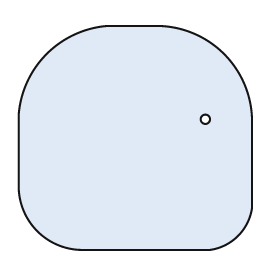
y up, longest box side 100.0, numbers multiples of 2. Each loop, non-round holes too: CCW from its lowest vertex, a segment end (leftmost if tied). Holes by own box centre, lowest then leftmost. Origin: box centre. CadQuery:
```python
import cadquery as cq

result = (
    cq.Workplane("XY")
    .moveTo(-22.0, -48.0)
    .lineTo(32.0, -48.0)
    .threePointArc((44.0, -42.0), (50.0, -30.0))
    .lineTo(50.0, 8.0)
    .threePointArc((38.0, 36.0), (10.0, 48.0))
    .lineTo(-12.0, 48.0)
    .threePointArc((-38.0, 36.0), (-50.0, 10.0))
    .lineTo(-50.0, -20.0)
    .threePointArc((-42.0, -40.0), (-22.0, -48.0))
    .close()
    .moveTo(30.0, 8.0)
    .circle(2.0)
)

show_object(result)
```